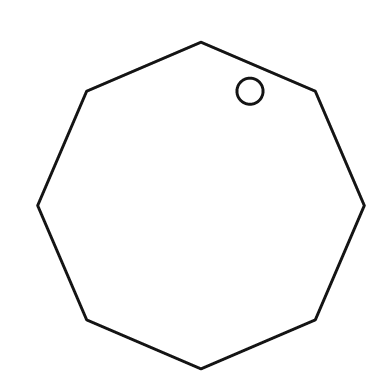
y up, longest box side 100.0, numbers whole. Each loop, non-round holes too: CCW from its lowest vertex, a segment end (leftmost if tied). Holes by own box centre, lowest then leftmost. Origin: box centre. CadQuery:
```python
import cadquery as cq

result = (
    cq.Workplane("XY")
    .moveTo(0.0, -50.0)
    .lineTo(35.0, -35.0)
    .lineTo(50.0, 0.0)
    .lineTo(35.0, 35.0)
    .lineTo(0.0, 50.0)
    .lineTo(-35.0, 35.0)
    .lineTo(-50.0, 0.0)
    .lineTo(-35.0, -35.0)
    .close()
    .moveTo(15.0, 35.0)
    .circle(4.0)
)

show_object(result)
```